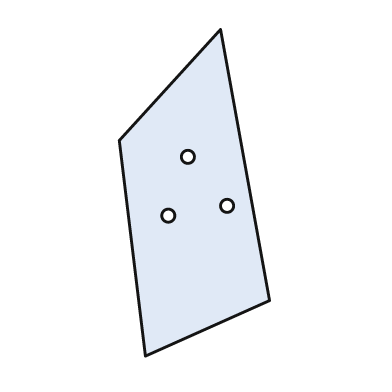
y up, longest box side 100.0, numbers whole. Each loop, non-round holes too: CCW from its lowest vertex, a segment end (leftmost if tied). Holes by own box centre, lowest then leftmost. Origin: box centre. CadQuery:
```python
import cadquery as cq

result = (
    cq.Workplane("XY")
    .moveTo(-15.0, -50.0)
    .lineTo(23.0, -33.0)
    .lineTo(8.0, 50.0)
    .lineTo(-23.0, 16.0)
    .close()
    .moveTo(-8.0, -7.0)
    .circle(2.0)
    .moveTo(10.0, -4.0)
    .circle(2.0)
    .moveTo(-2.0, 11.0)
    .circle(2.0)
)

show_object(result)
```